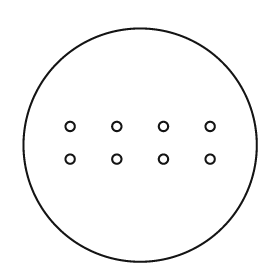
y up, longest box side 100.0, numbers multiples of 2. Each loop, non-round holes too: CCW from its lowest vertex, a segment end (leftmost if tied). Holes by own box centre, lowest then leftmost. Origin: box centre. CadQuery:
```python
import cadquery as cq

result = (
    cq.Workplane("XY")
    .moveTo(0.0, 0.0)
    .circle(50.0)
    .moveTo(-30.0, -6.0)
    .circle(2.0)
    .moveTo(-10.0, -6.0)
    .circle(2.0)
    .moveTo(10.0, -6.0)
    .circle(2.0)
    .moveTo(30.0, -6.0)
    .circle(2.0)
    .moveTo(-30.0, 8.0)
    .circle(2.0)
    .moveTo(-10.0, 8.0)
    .circle(2.0)
    .moveTo(10.0, 8.0)
    .circle(2.0)
    .moveTo(30.0, 8.0)
    .circle(2.0)
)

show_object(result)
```